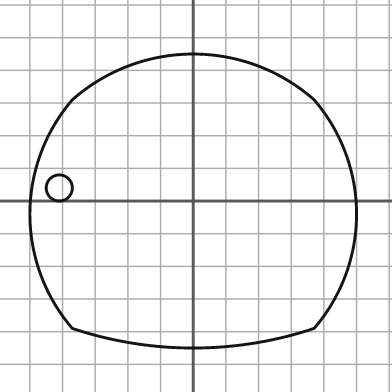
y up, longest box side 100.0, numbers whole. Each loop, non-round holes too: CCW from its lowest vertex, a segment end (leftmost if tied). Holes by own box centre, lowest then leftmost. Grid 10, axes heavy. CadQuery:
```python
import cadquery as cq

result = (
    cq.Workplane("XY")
    .moveTo(-37.0, -39.0)
    .threePointArc((0.0, -45.0), (37.0, -39.0))
    .threePointArc((50.0, -4.0), (37.0, 31.0))
    .threePointArc((0.0, 45.0), (-37.0, 31.0))
    .threePointArc((-50.0, -4.0), (-37.0, -39.0))
    .close()
    .moveTo(-41.0, 4.0)
    .circle(4.0)
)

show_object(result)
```